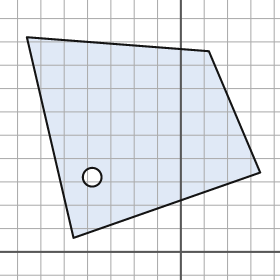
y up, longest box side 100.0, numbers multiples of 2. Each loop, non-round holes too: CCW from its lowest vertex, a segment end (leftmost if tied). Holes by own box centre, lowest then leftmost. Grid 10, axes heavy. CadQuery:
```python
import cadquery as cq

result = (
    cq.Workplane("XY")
    .moveTo(-46.0, 6.0)
    .lineTo(34.0, 34.0)
    .lineTo(12.0, 86.0)
    .lineTo(-66.0, 92.0)
    .close()
    .moveTo(-38.0, 32.0)
    .circle(4.0)
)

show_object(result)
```